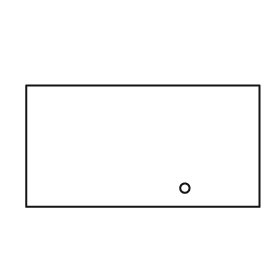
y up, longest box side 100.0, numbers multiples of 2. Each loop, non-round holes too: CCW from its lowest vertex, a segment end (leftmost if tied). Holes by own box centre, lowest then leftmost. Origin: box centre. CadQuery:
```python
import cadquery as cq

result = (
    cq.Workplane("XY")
    .moveTo(-50.0, -26.0)
    .lineTo(50.0, -26.0)
    .lineTo(50.0, 26.0)
    .lineTo(-50.0, 26.0)
    .close()
    .moveTo(18.0, -18.0)
    .circle(2.0)
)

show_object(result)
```